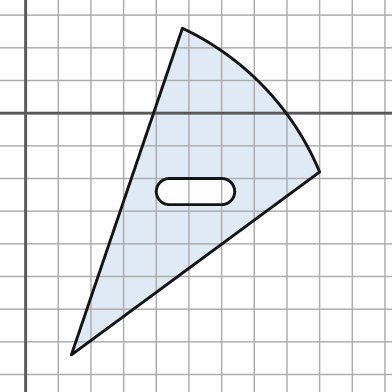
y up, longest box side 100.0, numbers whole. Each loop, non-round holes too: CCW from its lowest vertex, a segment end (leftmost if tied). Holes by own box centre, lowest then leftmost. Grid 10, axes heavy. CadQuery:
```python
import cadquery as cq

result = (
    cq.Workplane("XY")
    .moveTo(14.0, -74.0)
    .lineTo(90.0, -18.0)
    .threePointArc((73.0, 8.0), (48.0, 26.0))
    .close()
    .moveTo(44.0, -28.0)
    .lineTo(60.0, -28.0)
    .threePointArc((64.0, -24.0), (60.0, -20.0))
    .lineTo(44.0, -20.0)
    .threePointArc((40.0, -24.0), (44.0, -28.0))
    .close()
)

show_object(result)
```